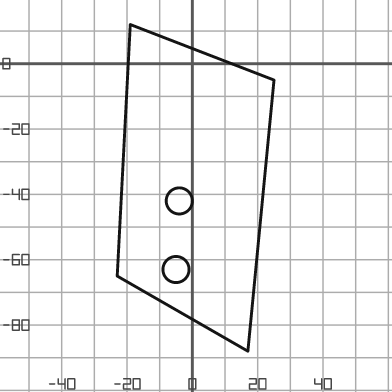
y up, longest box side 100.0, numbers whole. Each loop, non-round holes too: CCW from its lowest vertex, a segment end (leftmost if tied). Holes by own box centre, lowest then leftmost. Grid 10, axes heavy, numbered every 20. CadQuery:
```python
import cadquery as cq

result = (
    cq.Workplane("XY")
    .moveTo(17.0, -88.0)
    .lineTo(25.0, -5.0)
    .lineTo(-19.0, 12.0)
    .lineTo(-23.0, -65.0)
    .close()
    .moveTo(-5.0, -63.0)
    .circle(4.0)
    .moveTo(-4.0, -42.0)
    .circle(4.0)
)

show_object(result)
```